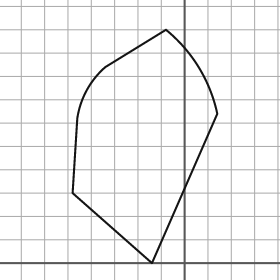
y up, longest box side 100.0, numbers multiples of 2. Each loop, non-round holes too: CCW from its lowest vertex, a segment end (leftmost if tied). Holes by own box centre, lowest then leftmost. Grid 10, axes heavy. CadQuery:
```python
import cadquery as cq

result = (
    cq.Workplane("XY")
    .moveTo(-14.0, 0.0)
    .lineTo(14.0, 64.0)
    .threePointArc((6.0, 84.0), (-8.0, 100.0))
    .lineTo(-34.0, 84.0)
    .threePointArc((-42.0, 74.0), (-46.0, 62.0))
    .lineTo(-48.0, 30.0)
    .close()
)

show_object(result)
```